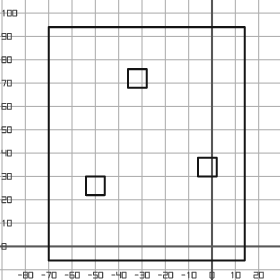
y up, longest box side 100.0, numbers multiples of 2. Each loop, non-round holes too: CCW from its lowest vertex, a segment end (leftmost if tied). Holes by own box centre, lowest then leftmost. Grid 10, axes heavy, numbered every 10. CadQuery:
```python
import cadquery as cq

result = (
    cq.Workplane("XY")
    .moveTo(-70.0, -6.0)
    .lineTo(14.0, -6.0)
    .lineTo(14.0, 94.0)
    .lineTo(-70.0, 94.0)
    .close()
    .moveTo(-54.0, 22.0)
    .lineTo(-46.0, 22.0)
    .lineTo(-46.0, 30.0)
    .lineTo(-54.0, 30.0)
    .close()
    .moveTo(-6.0, 30.0)
    .lineTo(2.0, 30.0)
    .lineTo(2.0, 38.0)
    .lineTo(-6.0, 38.0)
    .close()
    .moveTo(-36.0, 68.0)
    .lineTo(-28.0, 68.0)
    .lineTo(-28.0, 76.0)
    .lineTo(-36.0, 76.0)
    .close()
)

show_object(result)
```